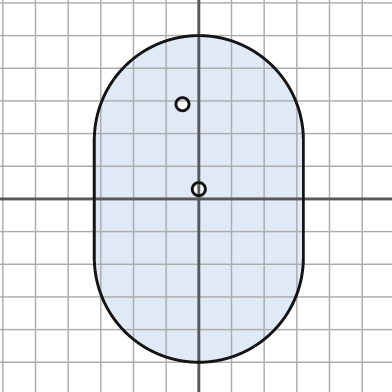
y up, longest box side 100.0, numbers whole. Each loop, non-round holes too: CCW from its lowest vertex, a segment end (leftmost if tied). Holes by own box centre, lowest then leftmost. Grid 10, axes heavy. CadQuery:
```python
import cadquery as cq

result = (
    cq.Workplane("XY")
    .moveTo(-32.0, -18.0)
    .threePointArc((0.0, -50.0), (32.0, -18.0))
    .lineTo(32.0, 18.0)
    .threePointArc((0.0, 50.0), (-32.0, 18.0))
    .close()
    .moveTo(0.0, 3.0)
    .circle(2.0)
    .moveTo(-5.0, 29.0)
    .circle(2.0)
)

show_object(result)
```